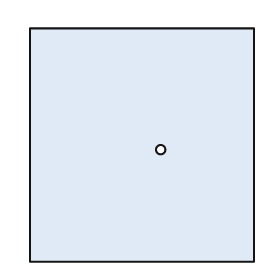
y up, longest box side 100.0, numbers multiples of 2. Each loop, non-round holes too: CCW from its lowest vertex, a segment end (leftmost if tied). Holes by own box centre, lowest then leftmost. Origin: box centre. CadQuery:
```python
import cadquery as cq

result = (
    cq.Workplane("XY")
    .moveTo(-48.0, -50.0)
    .lineTo(48.0, -50.0)
    .lineTo(48.0, 50.0)
    .lineTo(-48.0, 50.0)
    .close()
    .moveTo(8.0, -2.0)
    .circle(2.0)
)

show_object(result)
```